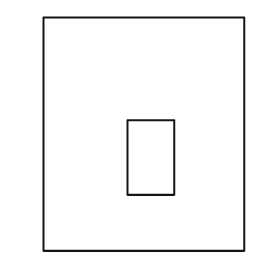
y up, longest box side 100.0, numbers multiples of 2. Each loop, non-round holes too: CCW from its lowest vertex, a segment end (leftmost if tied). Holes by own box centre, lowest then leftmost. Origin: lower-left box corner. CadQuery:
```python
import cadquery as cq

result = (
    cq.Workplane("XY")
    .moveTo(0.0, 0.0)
    .lineTo(86.0, 0.0)
    .lineTo(86.0, 100.0)
    .lineTo(0.0, 100.0)
    .close()
    .moveTo(36.0, 24.0)
    .lineTo(56.0, 24.0)
    .lineTo(56.0, 56.0)
    .lineTo(36.0, 56.0)
    .close()
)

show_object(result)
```